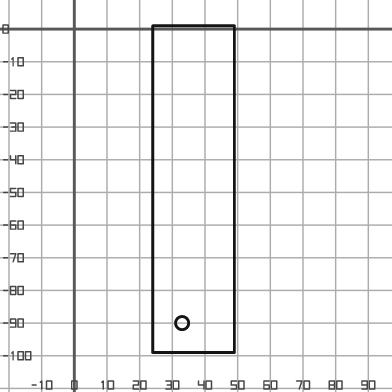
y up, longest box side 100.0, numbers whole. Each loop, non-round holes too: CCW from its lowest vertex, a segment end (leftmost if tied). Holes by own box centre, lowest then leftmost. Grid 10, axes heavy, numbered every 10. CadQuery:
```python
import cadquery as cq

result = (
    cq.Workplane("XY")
    .moveTo(24.0, -99.0)
    .lineTo(49.0, -99.0)
    .lineTo(49.0, 1.0)
    .lineTo(24.0, 1.0)
    .close()
    .moveTo(33.0, -90.0)
    .circle(2.0)
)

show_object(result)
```